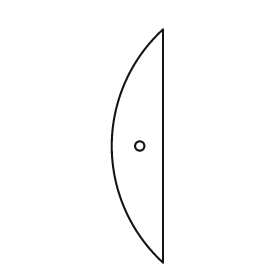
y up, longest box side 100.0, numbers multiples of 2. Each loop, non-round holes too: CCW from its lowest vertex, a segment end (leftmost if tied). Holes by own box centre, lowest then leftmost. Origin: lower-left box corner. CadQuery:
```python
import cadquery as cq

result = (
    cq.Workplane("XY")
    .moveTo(22.0, 0.0)
    .lineTo(22.0, 100.0)
    .threePointArc((0.0, 50.0), (22.0, 0.0))
    .close()
    .moveTo(12.0, 50.0)
    .circle(2.0)
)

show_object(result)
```